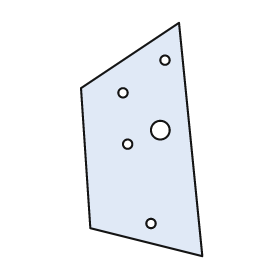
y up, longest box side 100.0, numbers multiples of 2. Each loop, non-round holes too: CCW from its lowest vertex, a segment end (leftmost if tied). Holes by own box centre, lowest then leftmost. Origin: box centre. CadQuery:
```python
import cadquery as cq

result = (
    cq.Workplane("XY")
    .moveTo(26.0, -50.0)
    .lineTo(16.0, 50.0)
    .lineTo(-26.0, 22.0)
    .lineTo(-22.0, -38.0)
    .close()
    .moveTo(4.0, -36.0)
    .circle(2.0)
    .moveTo(-6.0, -2.0)
    .circle(2.0)
    .moveTo(8.0, 4.0)
    .circle(4.0)
    .moveTo(-8.0, 20.0)
    .circle(2.0)
    .moveTo(10.0, 34.0)
    .circle(2.0)
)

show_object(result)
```